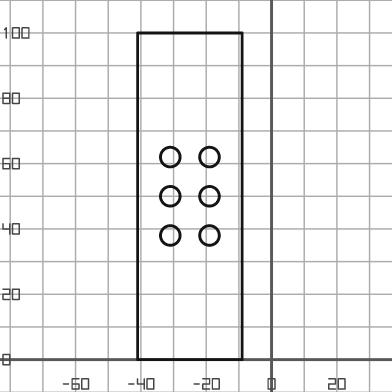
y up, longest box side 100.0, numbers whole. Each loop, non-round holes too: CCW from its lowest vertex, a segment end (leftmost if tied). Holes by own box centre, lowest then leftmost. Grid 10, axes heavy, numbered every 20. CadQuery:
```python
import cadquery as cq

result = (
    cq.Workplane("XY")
    .moveTo(-41.0, 0.0)
    .lineTo(-9.0, 0.0)
    .lineTo(-9.0, 100.0)
    .lineTo(-41.0, 100.0)
    .close()
    .moveTo(-31.0, 38.0)
    .circle(3.0)
    .moveTo(-19.0, 38.0)
    .circle(3.0)
    .moveTo(-31.0, 50.0)
    .circle(3.0)
    .moveTo(-19.0, 50.0)
    .circle(3.0)
    .moveTo(-31.0, 62.0)
    .circle(3.0)
    .moveTo(-19.0, 62.0)
    .circle(3.0)
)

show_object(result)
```